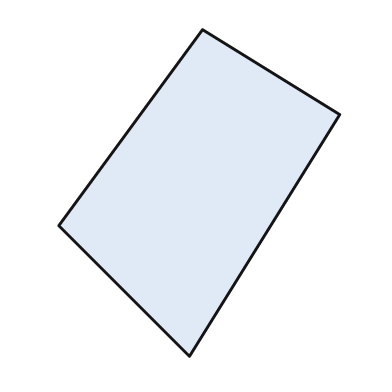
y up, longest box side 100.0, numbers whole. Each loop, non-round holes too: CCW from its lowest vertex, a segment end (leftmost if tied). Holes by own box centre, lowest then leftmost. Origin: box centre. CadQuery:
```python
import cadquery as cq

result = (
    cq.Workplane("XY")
    .moveTo(-3.0, -50.0)
    .lineTo(43.0, 24.0)
    .lineTo(1.0, 50.0)
    .lineTo(-43.0, -10.0)
    .close()
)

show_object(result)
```